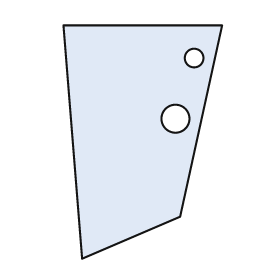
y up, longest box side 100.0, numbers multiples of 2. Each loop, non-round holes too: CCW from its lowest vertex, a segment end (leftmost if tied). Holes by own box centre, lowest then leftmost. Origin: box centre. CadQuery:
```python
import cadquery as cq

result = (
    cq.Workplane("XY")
    .moveTo(-26.0, -50.0)
    .lineTo(16.0, -32.0)
    .lineTo(34.0, 50.0)
    .lineTo(-34.0, 50.0)
    .close()
    .moveTo(14.0, 10.0)
    .circle(6.0)
    .moveTo(22.0, 36.0)
    .circle(4.0)
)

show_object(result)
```